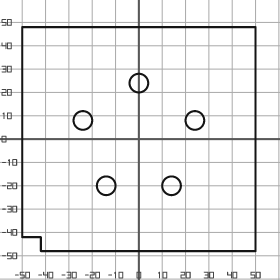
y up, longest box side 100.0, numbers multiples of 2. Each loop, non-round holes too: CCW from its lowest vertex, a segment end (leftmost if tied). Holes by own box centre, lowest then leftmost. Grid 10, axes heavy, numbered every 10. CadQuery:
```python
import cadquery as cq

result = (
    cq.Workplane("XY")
    .moveTo(-42.0, -48.0)
    .lineTo(50.0, -48.0)
    .lineTo(50.0, 48.0)
    .lineTo(-50.0, 48.0)
    .lineTo(-50.0, -42.0)
    .lineTo(-42.0, -42.0)
    .close()
    .moveTo(-14.0, -20.0)
    .circle(4.0)
    .moveTo(14.0, -20.0)
    .circle(4.0)
    .moveTo(-24.0, 8.0)
    .circle(4.0)
    .moveTo(24.0, 8.0)
    .circle(4.0)
    .moveTo(0.0, 24.0)
    .circle(4.0)
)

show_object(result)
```